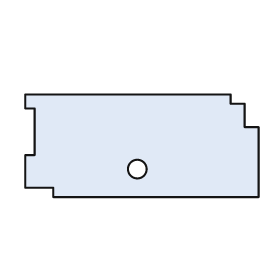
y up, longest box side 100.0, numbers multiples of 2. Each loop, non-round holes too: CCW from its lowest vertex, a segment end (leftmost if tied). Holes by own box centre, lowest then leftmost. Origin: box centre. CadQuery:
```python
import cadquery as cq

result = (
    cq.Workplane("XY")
    .moveTo(-38.0, -22.0)
    .lineTo(50.0, -22.0)
    .lineTo(50.0, 8.0)
    .lineTo(44.0, 8.0)
    .lineTo(44.0, 18.0)
    .lineTo(38.0, 18.0)
    .lineTo(38.0, 22.0)
    .lineTo(-50.0, 22.0)
    .lineTo(-50.0, 16.0)
    .lineTo(-46.0, 16.0)
    .lineTo(-46.0, -4.0)
    .lineTo(-50.0, -4.0)
    .lineTo(-50.0, -18.0)
    .lineTo(-38.0, -18.0)
    .close()
    .moveTo(-2.0, -10.0)
    .circle(4.0)
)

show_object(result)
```